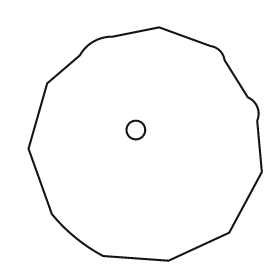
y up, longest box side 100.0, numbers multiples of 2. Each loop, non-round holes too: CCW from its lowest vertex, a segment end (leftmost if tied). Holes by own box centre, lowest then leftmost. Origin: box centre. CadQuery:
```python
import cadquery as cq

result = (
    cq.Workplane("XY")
    .moveTo(10.0, -50.0)
    .lineTo(36.0, -38.0)
    .lineTo(50.0, -12.0)
    .lineTo(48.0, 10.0)
    .threePointArc((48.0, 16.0), (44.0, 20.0))
    .lineTo(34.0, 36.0)
    .threePointArc((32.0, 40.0), (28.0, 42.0))
    .lineTo(6.0, 50.0)
    .lineTo(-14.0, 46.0)
    .threePointArc((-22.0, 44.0), (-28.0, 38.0))
    .lineTo(-42.0, 26.0)
    .lineTo(-50.0, -2.0)
    .lineTo(-40.0, -30.0)
    .threePointArc((-30.0, -40.0), (-18.0, -48.0))
    .close()
    .moveTo(-4.0, 6.0)
    .circle(4.0)
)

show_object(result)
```